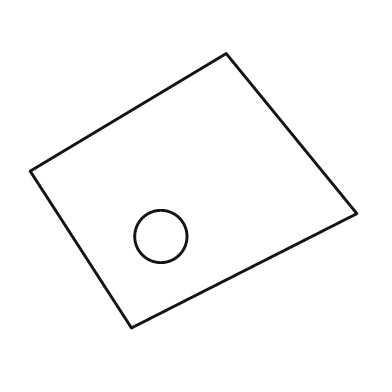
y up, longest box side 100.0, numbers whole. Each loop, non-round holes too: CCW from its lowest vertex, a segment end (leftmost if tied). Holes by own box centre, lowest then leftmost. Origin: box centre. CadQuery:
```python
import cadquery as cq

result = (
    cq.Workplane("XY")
    .moveTo(-19.0, -42.0)
    .lineTo(50.0, -7.0)
    .lineTo(10.0, 42.0)
    .lineTo(-50.0, 6.0)
    .close()
    .moveTo(-10.0, -14.0)
    .circle(8.0)
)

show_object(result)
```